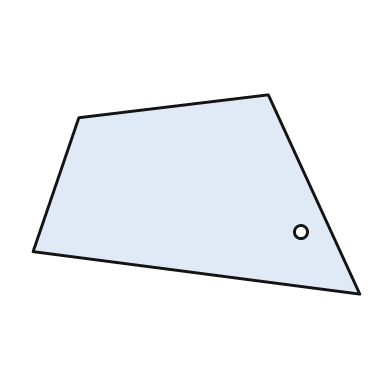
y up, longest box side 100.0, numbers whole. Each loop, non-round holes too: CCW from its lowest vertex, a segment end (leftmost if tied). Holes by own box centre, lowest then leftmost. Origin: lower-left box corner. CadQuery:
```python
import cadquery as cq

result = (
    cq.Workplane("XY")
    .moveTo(100.0, 0.0)
    .lineTo(72.0, 61.0)
    .lineTo(14.0, 54.0)
    .lineTo(0.0, 13.0)
    .close()
    .moveTo(82.0, 19.0)
    .circle(2.0)
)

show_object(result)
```